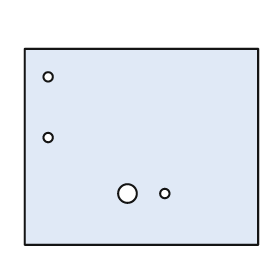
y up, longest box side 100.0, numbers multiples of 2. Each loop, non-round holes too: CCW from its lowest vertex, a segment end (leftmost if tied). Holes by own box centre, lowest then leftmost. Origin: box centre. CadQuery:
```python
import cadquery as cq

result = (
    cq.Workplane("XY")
    .moveTo(-50.0, -42.0)
    .lineTo(50.0, -42.0)
    .lineTo(50.0, 42.0)
    .lineTo(-50.0, 42.0)
    .close()
    .moveTo(-6.0, -20.0)
    .circle(4.0)
    .moveTo(10.0, -20.0)
    .circle(2.0)
    .moveTo(-40.0, 4.0)
    .circle(2.0)
    .moveTo(-40.0, 30.0)
    .circle(2.0)
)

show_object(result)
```